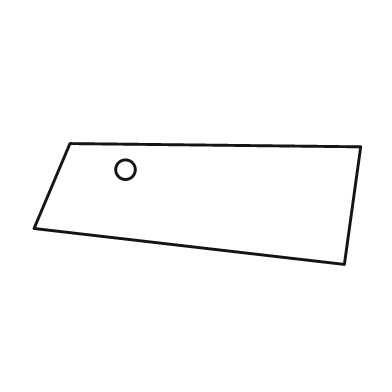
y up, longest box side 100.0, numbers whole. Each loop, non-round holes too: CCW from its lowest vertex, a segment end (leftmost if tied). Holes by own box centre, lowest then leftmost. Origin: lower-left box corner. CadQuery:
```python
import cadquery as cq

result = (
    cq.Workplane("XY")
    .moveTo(95.0, 0.0)
    .lineTo(100.0, 36.0)
    .lineTo(11.0, 37.0)
    .lineTo(0.0, 11.0)
    .close()
    .moveTo(28.0, 29.0)
    .circle(3.0)
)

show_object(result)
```